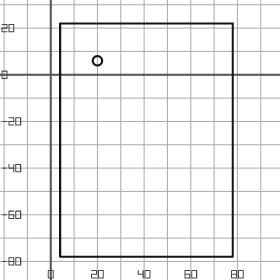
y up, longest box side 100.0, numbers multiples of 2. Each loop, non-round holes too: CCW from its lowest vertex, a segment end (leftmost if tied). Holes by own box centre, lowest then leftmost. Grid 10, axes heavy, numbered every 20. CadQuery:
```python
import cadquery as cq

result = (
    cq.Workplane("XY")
    .moveTo(4.0, -78.0)
    .lineTo(78.0, -78.0)
    .lineTo(78.0, 22.0)
    .lineTo(4.0, 22.0)
    .close()
    .moveTo(20.0, 6.0)
    .circle(2.0)
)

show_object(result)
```